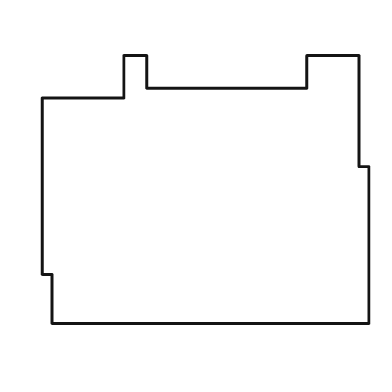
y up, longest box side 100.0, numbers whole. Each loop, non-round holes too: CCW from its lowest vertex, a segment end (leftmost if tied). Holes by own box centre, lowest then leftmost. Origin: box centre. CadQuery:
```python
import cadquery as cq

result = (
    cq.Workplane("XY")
    .moveTo(-47.0, -41.0)
    .lineTo(50.0, -41.0)
    .lineTo(50.0, 7.0)
    .lineTo(47.0, 7.0)
    .lineTo(47.0, 41.0)
    .lineTo(31.0, 41.0)
    .lineTo(31.0, 31.0)
    .lineTo(-18.0, 31.0)
    .lineTo(-18.0, 41.0)
    .lineTo(-25.0, 41.0)
    .lineTo(-25.0, 28.0)
    .lineTo(-50.0, 28.0)
    .lineTo(-50.0, -26.0)
    .lineTo(-47.0, -26.0)
    .close()
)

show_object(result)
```